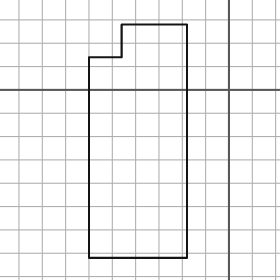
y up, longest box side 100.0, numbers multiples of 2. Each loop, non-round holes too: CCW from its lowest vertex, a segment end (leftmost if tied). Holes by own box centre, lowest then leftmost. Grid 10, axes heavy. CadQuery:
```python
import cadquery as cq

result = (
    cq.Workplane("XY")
    .moveTo(-60.0, -72.0)
    .lineTo(-18.0, -72.0)
    .lineTo(-18.0, 28.0)
    .lineTo(-46.0, 28.0)
    .lineTo(-46.0, 14.0)
    .lineTo(-60.0, 14.0)
    .close()
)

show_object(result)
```